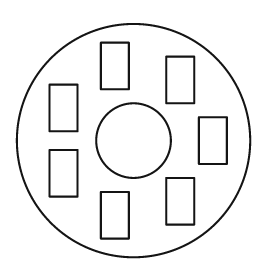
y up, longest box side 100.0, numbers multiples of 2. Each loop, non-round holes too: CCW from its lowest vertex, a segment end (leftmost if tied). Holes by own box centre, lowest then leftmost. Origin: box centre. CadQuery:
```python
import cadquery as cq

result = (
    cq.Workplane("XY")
    .moveTo(0.0, 0.0)
    .circle(50.0)
    .moveTo(-14.0, -42.0)
    .lineTo(-2.0, -42.0)
    .lineTo(-2.0, -22.0)
    .lineTo(-14.0, -22.0)
    .close()
    .moveTo(14.0, -36.0)
    .lineTo(26.0, -36.0)
    .lineTo(26.0, -16.0)
    .lineTo(14.0, -16.0)
    .close()
    .moveTo(-36.0, -24.0)
    .lineTo(-24.0, -24.0)
    .lineTo(-24.0, -4.0)
    .lineTo(-36.0, -4.0)
    .close()
    .moveTo(0.0, 0.0)
    .circle(16.0)
    .moveTo(28.0, -10.0)
    .lineTo(40.0, -10.0)
    .lineTo(40.0, 10.0)
    .lineTo(28.0, 10.0)
    .close()
    .moveTo(-36.0, 4.0)
    .lineTo(-24.0, 4.0)
    .lineTo(-24.0, 24.0)
    .lineTo(-36.0, 24.0)
    .close()
    .moveTo(14.0, 16.0)
    .lineTo(26.0, 16.0)
    .lineTo(26.0, 36.0)
    .lineTo(14.0, 36.0)
    .close()
    .moveTo(-14.0, 22.0)
    .lineTo(-2.0, 22.0)
    .lineTo(-2.0, 42.0)
    .lineTo(-14.0, 42.0)
    .close()
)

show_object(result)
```